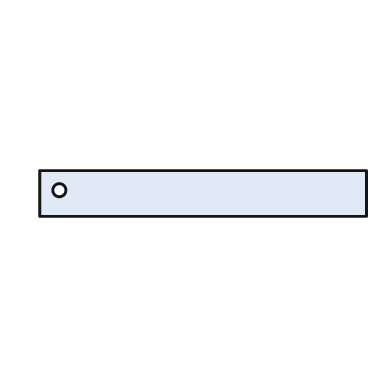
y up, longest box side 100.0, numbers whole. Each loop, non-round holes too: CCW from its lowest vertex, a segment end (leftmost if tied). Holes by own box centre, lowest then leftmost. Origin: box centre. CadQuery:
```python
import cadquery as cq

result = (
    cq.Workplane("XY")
    .moveTo(-50.0, -7.0)
    .lineTo(50.0, -7.0)
    .lineTo(50.0, 7.0)
    .lineTo(-50.0, 7.0)
    .close()
    .moveTo(-44.0, 1.0)
    .circle(2.0)
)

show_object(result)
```